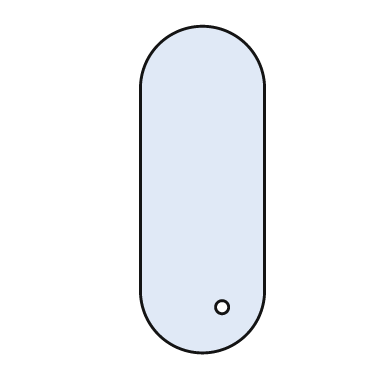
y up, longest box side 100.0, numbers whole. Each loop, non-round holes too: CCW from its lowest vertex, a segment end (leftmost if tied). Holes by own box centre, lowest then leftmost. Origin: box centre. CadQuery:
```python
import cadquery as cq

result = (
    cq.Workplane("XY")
    .moveTo(-19.0, -31.0)
    .threePointArc((0.0, -50.0), (19.0, -31.0))
    .lineTo(19.0, 31.0)
    .threePointArc((0.0, 50.0), (-19.0, 31.0))
    .close()
    .moveTo(6.0, -36.0)
    .circle(2.0)
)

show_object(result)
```